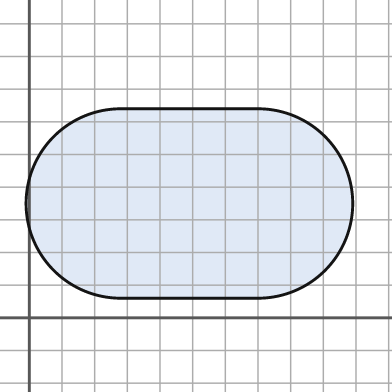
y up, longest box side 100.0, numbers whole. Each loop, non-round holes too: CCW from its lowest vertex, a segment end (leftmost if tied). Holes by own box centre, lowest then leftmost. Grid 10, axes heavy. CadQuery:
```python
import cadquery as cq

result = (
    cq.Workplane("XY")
    .moveTo(28.0, 6.0)
    .lineTo(70.0, 6.0)
    .threePointArc((99.0, 35.0), (70.0, 64.0))
    .lineTo(28.0, 64.0)
    .threePointArc((-1.0, 35.0), (28.0, 6.0))
    .close()
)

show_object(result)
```